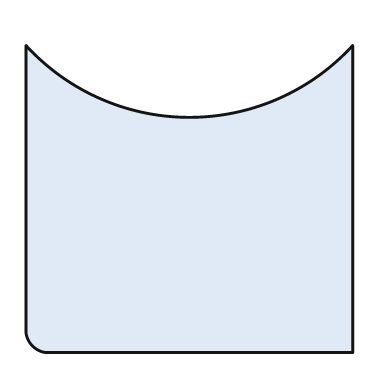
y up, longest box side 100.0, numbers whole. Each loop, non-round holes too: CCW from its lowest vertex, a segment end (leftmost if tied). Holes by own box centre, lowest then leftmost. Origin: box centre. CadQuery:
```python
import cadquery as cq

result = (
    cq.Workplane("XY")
    .moveTo(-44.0, -47.0)
    .lineTo(50.0, -47.0)
    .lineTo(50.0, 47.0)
    .threePointArc((0.0, 25.0), (-50.0, 47.0))
    .lineTo(-50.0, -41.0)
    .threePointArc((-48.0, -45.0), (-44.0, -47.0))
    .close()
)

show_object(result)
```